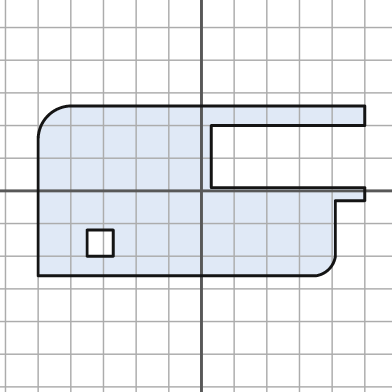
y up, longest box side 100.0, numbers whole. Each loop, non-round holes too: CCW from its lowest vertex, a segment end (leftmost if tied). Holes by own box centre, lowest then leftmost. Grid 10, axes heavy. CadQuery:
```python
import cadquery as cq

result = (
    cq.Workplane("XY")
    .moveTo(-50.0, -26.0)
    .lineTo(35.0, -26.0)
    .threePointArc((39.0, -24.0), (41.0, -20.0))
    .lineTo(41.0, -3.0)
    .lineTo(50.0, -3.0)
    .lineTo(50.0, 1.0)
    .lineTo(3.0, 1.0)
    .lineTo(3.0, 20.0)
    .lineTo(50.0, 20.0)
    .lineTo(50.0, 26.0)
    .lineTo(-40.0, 26.0)
    .threePointArc((-47.0, 23.0), (-50.0, 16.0))
    .close()
    .moveTo(-35.0, -20.0)
    .lineTo(-27.0, -20.0)
    .lineTo(-27.0, -12.0)
    .lineTo(-35.0, -12.0)
    .close()
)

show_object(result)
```